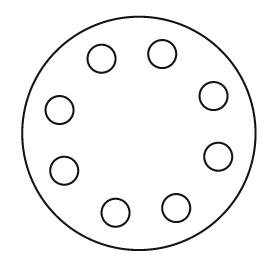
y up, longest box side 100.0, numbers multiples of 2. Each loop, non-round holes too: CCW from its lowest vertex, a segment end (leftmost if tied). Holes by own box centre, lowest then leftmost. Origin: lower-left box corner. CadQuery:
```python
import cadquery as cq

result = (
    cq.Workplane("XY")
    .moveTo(50.0, 50.0)
    .circle(50.0)
    .moveTo(40.0, 16.0)
    .circle(6.0)
    .moveTo(66.0, 18.0)
    .circle(6.0)
    .moveTo(18.0, 34.0)
    .circle(6.0)
    .moveTo(84.0, 40.0)
    .circle(6.0)
    .moveTo(16.0, 60.0)
    .circle(6.0)
    .moveTo(82.0, 66.0)
    .circle(6.0)
    .moveTo(34.0, 82.0)
    .circle(6.0)
    .moveTo(60.0, 84.0)
    .circle(6.0)
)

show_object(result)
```